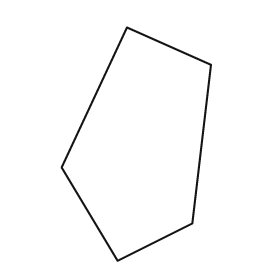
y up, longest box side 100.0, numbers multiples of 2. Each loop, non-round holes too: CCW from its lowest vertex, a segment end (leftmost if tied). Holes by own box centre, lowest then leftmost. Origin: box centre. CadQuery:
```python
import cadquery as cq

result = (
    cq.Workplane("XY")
    .moveTo(-8.0, -50.0)
    .lineTo(24.0, -34.0)
    .lineTo(32.0, 34.0)
    .lineTo(-4.0, 50.0)
    .lineTo(-32.0, -10.0)
    .close()
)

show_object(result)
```